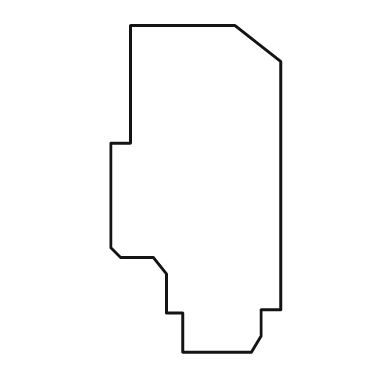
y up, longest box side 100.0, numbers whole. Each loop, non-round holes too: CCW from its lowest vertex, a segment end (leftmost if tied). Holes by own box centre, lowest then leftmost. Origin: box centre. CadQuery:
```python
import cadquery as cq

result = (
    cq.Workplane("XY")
    .moveTo(-4.0, -50.0)
    .lineTo(17.0, -50.0)
    .lineTo(20.0, -45.0)
    .lineTo(20.0, -37.0)
    .lineTo(26.0, -37.0)
    .lineTo(26.0, 39.0)
    .lineTo(12.0, 50.0)
    .lineTo(-20.0, 50.0)
    .lineTo(-20.0, 14.0)
    .lineTo(-26.0, 14.0)
    .lineTo(-26.0, -18.0)
    .lineTo(-23.0, -21.0)
    .lineTo(-13.0, -21.0)
    .lineTo(-9.0, -26.0)
    .lineTo(-9.0, -38.0)
    .lineTo(-4.0, -38.0)
    .close()
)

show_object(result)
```